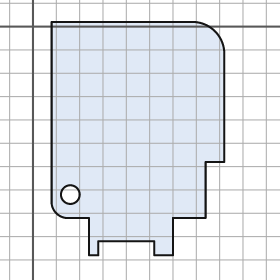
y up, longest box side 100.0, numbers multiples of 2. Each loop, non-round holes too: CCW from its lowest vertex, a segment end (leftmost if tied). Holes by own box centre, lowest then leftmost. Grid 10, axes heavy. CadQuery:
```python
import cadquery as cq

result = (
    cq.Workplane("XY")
    .moveTo(24.0, -98.0)
    .lineTo(28.0, -98.0)
    .lineTo(28.0, -92.0)
    .lineTo(52.0, -92.0)
    .lineTo(52.0, -98.0)
    .lineTo(60.0, -98.0)
    .lineTo(60.0, -82.0)
    .lineTo(74.0, -82.0)
    .lineTo(74.0, -58.0)
    .lineTo(82.0, -58.0)
    .lineTo(82.0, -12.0)
    .threePointArc((78.0, -2.0), (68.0, 2.0))
    .lineTo(8.0, 2.0)
    .lineTo(8.0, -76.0)
    .threePointArc((10.0, -80.0), (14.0, -82.0))
    .lineTo(24.0, -82.0)
    .close()
    .moveTo(16.0, -72.0)
    .circle(4.0)
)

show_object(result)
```